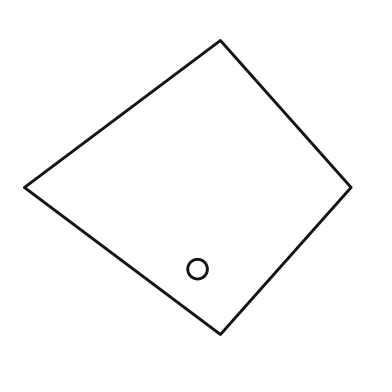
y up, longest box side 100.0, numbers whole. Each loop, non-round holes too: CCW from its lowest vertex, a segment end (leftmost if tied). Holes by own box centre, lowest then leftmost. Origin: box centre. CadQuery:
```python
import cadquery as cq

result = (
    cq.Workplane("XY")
    .moveTo(10.0, -45.0)
    .lineTo(50.0, 0.0)
    .lineTo(10.0, 45.0)
    .lineTo(-50.0, 0.0)
    .close()
    .moveTo(3.0, -25.0)
    .circle(3.0)
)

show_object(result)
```